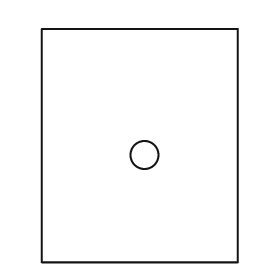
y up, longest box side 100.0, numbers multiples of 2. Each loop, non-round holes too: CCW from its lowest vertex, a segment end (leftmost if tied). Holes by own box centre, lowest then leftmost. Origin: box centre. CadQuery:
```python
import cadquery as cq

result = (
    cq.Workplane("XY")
    .moveTo(-42.0, -50.0)
    .lineTo(42.0, -50.0)
    .lineTo(42.0, 50.0)
    .lineTo(-42.0, 50.0)
    .close()
    .moveTo(2.0, -4.0)
    .circle(6.0)
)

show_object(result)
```